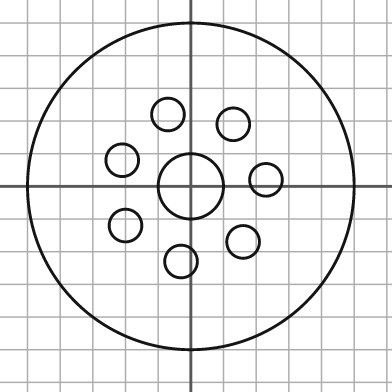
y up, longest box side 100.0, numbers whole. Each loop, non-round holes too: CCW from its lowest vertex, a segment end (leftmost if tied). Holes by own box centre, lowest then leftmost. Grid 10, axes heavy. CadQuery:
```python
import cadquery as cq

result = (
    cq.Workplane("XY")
    .moveTo(0.0, 0.0)
    .circle(50.0)
    .moveTo(-3.0, -23.0)
    .circle(5.0)
    .moveTo(16.0, -17.0)
    .circle(5.0)
    .moveTo(-20.0, -12.0)
    .circle(5.0)
    .moveTo(0.0, 0.0)
    .circle(10.0)
    .moveTo(23.0, 2.0)
    .circle(5.0)
    .moveTo(-21.0, 8.0)
    .circle(5.0)
    .moveTo(13.0, 19.0)
    .circle(5.0)
    .moveTo(-7.0, 22.0)
    .circle(5.0)
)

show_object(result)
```